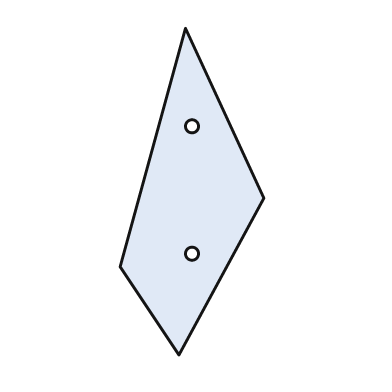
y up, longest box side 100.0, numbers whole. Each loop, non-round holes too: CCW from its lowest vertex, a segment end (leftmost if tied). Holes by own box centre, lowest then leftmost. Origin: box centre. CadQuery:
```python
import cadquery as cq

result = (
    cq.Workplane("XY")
    .moveTo(-4.0, -50.0)
    .lineTo(22.0, -2.0)
    .lineTo(-2.0, 50.0)
    .lineTo(-22.0, -23.0)
    .close()
    .moveTo(0.0, -19.0)
    .circle(2.0)
    .moveTo(0.0, 20.0)
    .circle(2.0)
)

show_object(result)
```